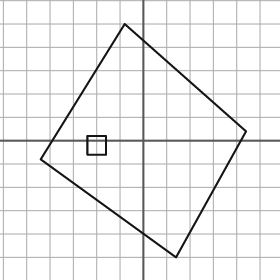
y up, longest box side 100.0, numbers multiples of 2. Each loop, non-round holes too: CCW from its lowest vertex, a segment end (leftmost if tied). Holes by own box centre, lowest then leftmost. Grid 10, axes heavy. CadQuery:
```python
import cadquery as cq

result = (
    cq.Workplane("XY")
    .moveTo(14.0, -50.0)
    .lineTo(44.0, 4.0)
    .lineTo(-8.0, 50.0)
    .lineTo(-44.0, -8.0)
    .close()
    .moveTo(-24.0, -6.0)
    .lineTo(-16.0, -6.0)
    .lineTo(-16.0, 2.0)
    .lineTo(-24.0, 2.0)
    .close()
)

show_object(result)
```